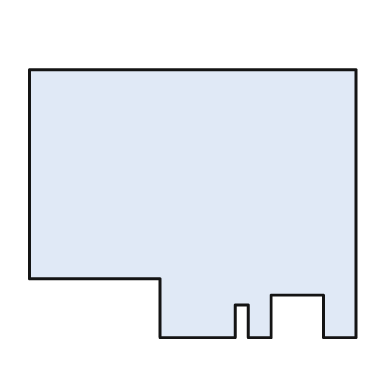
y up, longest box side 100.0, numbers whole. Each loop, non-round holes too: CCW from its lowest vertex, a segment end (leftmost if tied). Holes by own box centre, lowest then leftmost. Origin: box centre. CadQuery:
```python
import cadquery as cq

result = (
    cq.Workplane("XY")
    .moveTo(-10.0, -41.0)
    .lineTo(13.0, -41.0)
    .lineTo(13.0, -31.0)
    .lineTo(17.0, -31.0)
    .lineTo(17.0, -41.0)
    .lineTo(24.0, -41.0)
    .lineTo(24.0, -28.0)
    .lineTo(40.0, -28.0)
    .lineTo(40.0, -41.0)
    .lineTo(50.0, -41.0)
    .lineTo(50.0, 41.0)
    .lineTo(-50.0, 41.0)
    .lineTo(-50.0, -23.0)
    .lineTo(-10.0, -23.0)
    .close()
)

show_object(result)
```